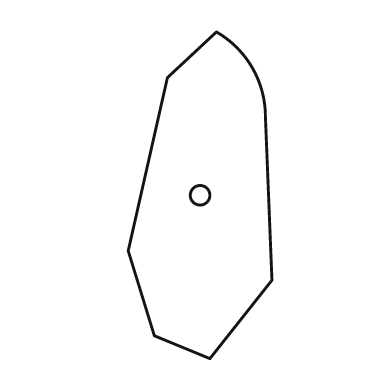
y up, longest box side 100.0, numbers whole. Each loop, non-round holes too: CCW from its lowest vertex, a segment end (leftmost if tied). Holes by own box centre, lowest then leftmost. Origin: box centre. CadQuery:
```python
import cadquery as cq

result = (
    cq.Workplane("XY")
    .moveTo(3.0, -50.0)
    .lineTo(22.0, -26.0)
    .lineTo(20.0, 24.0)
    .threePointArc((16.0, 39.0), (5.0, 50.0))
    .lineTo(-10.0, 36.0)
    .lineTo(-22.0, -17.0)
    .lineTo(-14.0, -43.0)
    .close()
    .moveTo(0.0, 0.0)
    .circle(3.0)
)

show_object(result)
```